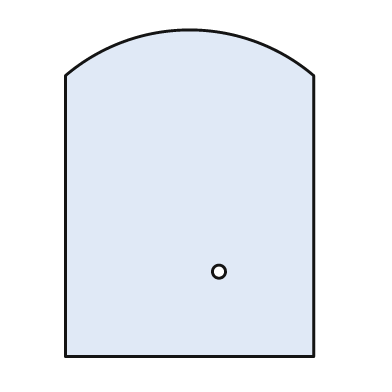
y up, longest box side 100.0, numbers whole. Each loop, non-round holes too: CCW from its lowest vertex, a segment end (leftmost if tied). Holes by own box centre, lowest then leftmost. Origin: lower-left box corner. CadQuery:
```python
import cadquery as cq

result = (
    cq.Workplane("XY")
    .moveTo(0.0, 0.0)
    .lineTo(76.0, 0.0)
    .lineTo(76.0, 86.0)
    .threePointArc((38.0, 100.0), (0.0, 86.0))
    .close()
    .moveTo(47.0, 26.0)
    .circle(2.0)
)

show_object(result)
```